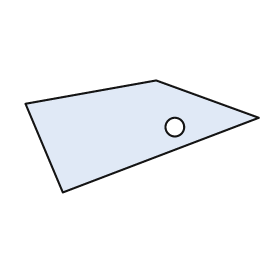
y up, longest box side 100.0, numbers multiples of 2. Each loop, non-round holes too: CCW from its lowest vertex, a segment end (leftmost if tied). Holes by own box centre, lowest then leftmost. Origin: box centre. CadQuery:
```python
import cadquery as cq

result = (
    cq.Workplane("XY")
    .moveTo(-34.0, -24.0)
    .lineTo(50.0, 8.0)
    .lineTo(6.0, 24.0)
    .lineTo(-50.0, 14.0)
    .close()
    .moveTo(14.0, 4.0)
    .circle(4.0)
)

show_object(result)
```